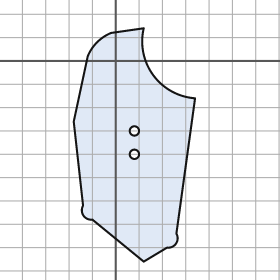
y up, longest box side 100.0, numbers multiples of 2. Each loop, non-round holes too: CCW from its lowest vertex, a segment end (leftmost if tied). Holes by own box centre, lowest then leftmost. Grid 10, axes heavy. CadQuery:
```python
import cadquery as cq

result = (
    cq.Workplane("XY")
    .moveTo(12.0, -86.0)
    .lineTo(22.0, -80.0)
    .threePointArc((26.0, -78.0), (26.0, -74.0))
    .lineTo(34.0, -16.0)
    .threePointArc((16.0, -6.0), (12.0, 14.0))
    .lineTo(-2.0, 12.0)
    .threePointArc((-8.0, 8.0), (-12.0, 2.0))
    .lineTo(-18.0, -26.0)
    .lineTo(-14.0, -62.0)
    .threePointArc((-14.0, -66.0), (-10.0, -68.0))
    .close()
    .moveTo(8.0, -40.0)
    .circle(2.0)
    .moveTo(8.0, -30.0)
    .circle(2.0)
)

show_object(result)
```